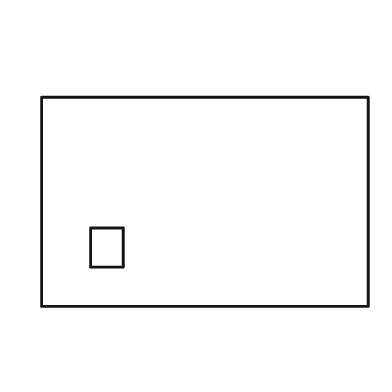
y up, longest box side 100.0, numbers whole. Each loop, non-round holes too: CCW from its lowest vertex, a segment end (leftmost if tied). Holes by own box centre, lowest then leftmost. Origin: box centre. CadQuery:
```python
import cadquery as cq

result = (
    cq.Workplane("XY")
    .moveTo(-50.0, -32.0)
    .lineTo(50.0, -32.0)
    .lineTo(50.0, 32.0)
    .lineTo(-50.0, 32.0)
    .close()
    .moveTo(-35.0, -20.0)
    .lineTo(-25.0, -20.0)
    .lineTo(-25.0, -8.0)
    .lineTo(-35.0, -8.0)
    .close()
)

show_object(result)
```